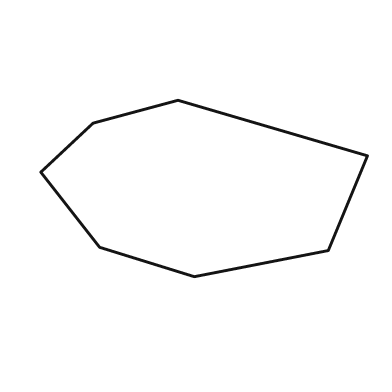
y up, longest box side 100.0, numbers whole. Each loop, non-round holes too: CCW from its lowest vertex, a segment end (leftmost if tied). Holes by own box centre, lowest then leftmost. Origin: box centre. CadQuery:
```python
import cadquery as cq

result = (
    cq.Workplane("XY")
    .moveTo(-3.0, -27.0)
    .lineTo(38.0, -19.0)
    .lineTo(50.0, 10.0)
    .lineTo(-8.0, 27.0)
    .lineTo(-34.0, 20.0)
    .lineTo(-50.0, 5.0)
    .lineTo(-32.0, -18.0)
    .close()
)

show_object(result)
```